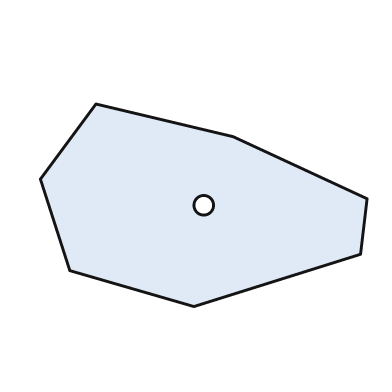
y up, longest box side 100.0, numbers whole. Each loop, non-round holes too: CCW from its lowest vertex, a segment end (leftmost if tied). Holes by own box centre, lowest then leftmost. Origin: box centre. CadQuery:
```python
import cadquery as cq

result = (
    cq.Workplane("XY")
    .moveTo(-3.0, -31.0)
    .lineTo(48.0, -15.0)
    .lineTo(50.0, 2.0)
    .lineTo(9.0, 21.0)
    .lineTo(-33.0, 31.0)
    .lineTo(-50.0, 8.0)
    .lineTo(-41.0, -20.0)
    .close()
    .moveTo(0.0, 0.0)
    .circle(3.0)
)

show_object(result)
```